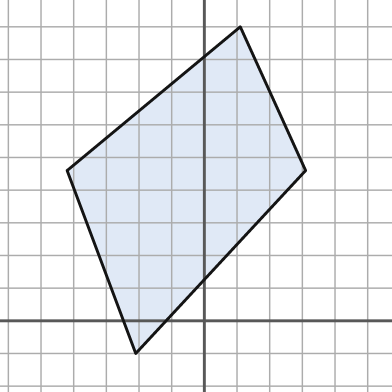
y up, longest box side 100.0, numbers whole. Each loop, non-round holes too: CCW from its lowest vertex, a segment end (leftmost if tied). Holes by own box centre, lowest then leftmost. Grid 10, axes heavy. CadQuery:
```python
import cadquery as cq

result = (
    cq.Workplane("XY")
    .moveTo(-21.0, -10.0)
    .lineTo(31.0, 46.0)
    .lineTo(11.0, 90.0)
    .lineTo(-42.0, 46.0)
    .close()
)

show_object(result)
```